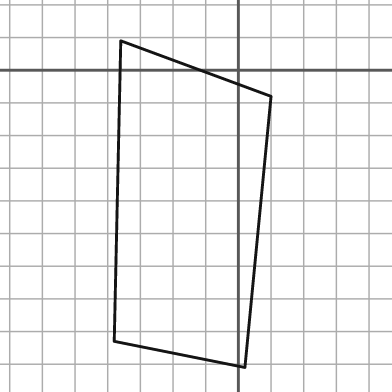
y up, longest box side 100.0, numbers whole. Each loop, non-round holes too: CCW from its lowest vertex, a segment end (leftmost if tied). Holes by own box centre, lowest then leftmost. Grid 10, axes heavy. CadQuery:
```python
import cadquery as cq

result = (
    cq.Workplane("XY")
    .moveTo(2.0, -91.0)
    .lineTo(10.0, -8.0)
    .lineTo(-36.0, 9.0)
    .lineTo(-38.0, -83.0)
    .close()
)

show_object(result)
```